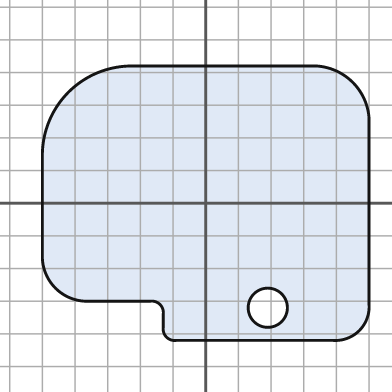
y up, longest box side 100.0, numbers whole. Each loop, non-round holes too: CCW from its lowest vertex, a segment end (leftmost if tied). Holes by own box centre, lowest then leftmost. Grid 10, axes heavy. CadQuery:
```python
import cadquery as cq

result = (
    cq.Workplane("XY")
    .moveTo(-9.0, -42.0)
    .lineTo(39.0, -42.0)
    .threePointArc((47.0, -39.0), (50.0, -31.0))
    .lineTo(50.0, 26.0)
    .threePointArc((45.0, 37.0), (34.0, 42.0))
    .lineTo(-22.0, 42.0)
    .threePointArc((-42.0, 34.0), (-50.0, 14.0))
    .lineTo(-50.0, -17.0)
    .threePointArc((-46.0, -26.0), (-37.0, -30.0))
    .lineTo(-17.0, -30.0)
    .threePointArc((-14.0, -31.0), (-13.0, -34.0))
    .lineTo(-13.0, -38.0)
    .threePointArc((-12.0, -41.0), (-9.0, -42.0))
    .close()
    .moveTo(19.0, -32.0)
    .circle(6.0)
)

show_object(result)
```